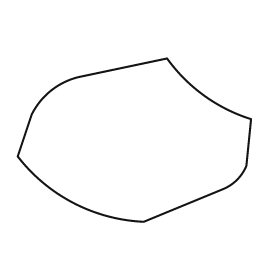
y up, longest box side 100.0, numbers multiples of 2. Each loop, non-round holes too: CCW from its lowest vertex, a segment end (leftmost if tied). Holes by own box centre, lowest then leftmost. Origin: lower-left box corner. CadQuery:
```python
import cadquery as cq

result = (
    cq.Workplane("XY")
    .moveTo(54.0, 0.0)
    .lineTo(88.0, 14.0)
    .threePointArc((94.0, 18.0), (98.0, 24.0))
    .lineTo(100.0, 44.0)
    .threePointArc((80.0, 54.0), (64.0, 70.0))
    .lineTo(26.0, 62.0)
    .threePointArc((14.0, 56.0), (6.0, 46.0))
    .lineTo(0.0, 28.0)
    .threePointArc((24.0, 8.0), (54.0, 0.0))
    .close()
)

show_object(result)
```